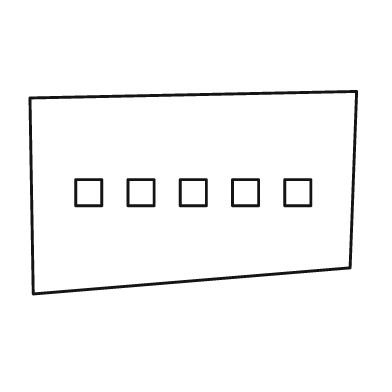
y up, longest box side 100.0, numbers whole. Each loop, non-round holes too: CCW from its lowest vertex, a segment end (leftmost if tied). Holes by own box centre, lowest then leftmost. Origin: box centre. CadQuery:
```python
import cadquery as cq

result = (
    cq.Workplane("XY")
    .moveTo(-49.0, -31.0)
    .lineTo(48.0, -23.0)
    .lineTo(50.0, 31.0)
    .lineTo(-50.0, 29.0)
    .close()
    .moveTo(-36.0, -4.0)
    .lineTo(-28.0, -4.0)
    .lineTo(-28.0, 4.0)
    .lineTo(-36.0, 4.0)
    .close()
    .moveTo(-20.0, -4.0)
    .lineTo(-12.0, -4.0)
    .lineTo(-12.0, 4.0)
    .lineTo(-20.0, 4.0)
    .close()
    .moveTo(-4.0, -4.0)
    .lineTo(4.0, -4.0)
    .lineTo(4.0, 4.0)
    .lineTo(-4.0, 4.0)
    .close()
    .moveTo(12.0, -4.0)
    .lineTo(20.0, -4.0)
    .lineTo(20.0, 4.0)
    .lineTo(12.0, 4.0)
    .close()
    .moveTo(28.0, -4.0)
    .lineTo(36.0, -4.0)
    .lineTo(36.0, 4.0)
    .lineTo(28.0, 4.0)
    .close()
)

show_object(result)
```